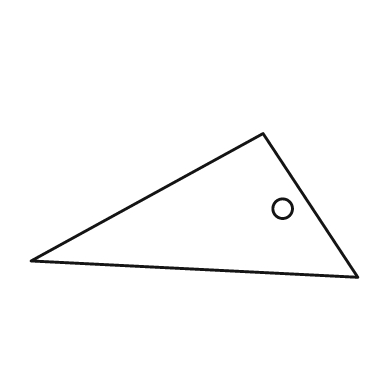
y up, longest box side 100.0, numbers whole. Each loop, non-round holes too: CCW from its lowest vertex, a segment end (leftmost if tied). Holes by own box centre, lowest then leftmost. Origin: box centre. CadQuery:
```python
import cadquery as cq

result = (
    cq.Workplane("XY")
    .moveTo(50.0, -22.0)
    .lineTo(21.0, 22.0)
    .lineTo(-50.0, -17.0)
    .close()
    .moveTo(27.0, -1.0)
    .circle(3.0)
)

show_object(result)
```